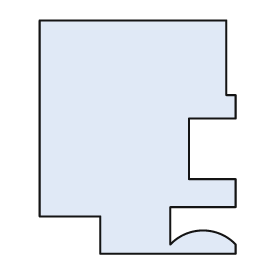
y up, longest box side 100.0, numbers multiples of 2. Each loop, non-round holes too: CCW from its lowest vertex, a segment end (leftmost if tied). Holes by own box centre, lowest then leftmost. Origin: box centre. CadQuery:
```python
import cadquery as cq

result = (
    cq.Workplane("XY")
    .moveTo(-16.0, -50.0)
    .lineTo(42.0, -50.0)
    .lineTo(42.0, -46.0)
    .threePointArc((28.0, -40.0), (14.0, -46.0))
    .lineTo(14.0, -30.0)
    .lineTo(42.0, -30.0)
    .lineTo(42.0, -18.0)
    .lineTo(22.0, -18.0)
    .lineTo(22.0, 8.0)
    .lineTo(42.0, 8.0)
    .lineTo(42.0, 18.0)
    .lineTo(38.0, 18.0)
    .lineTo(38.0, 50.0)
    .lineTo(-42.0, 50.0)
    .lineTo(-42.0, -34.0)
    .lineTo(-16.0, -34.0)
    .close()
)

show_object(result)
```